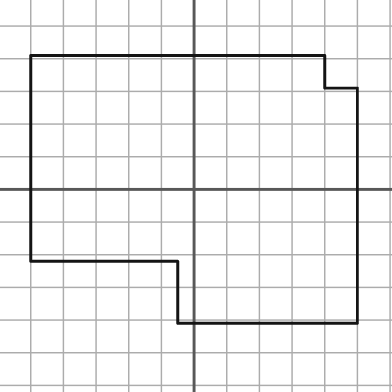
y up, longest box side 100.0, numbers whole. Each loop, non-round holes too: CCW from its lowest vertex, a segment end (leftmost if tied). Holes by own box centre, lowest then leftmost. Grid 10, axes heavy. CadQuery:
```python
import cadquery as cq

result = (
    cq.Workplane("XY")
    .moveTo(-5.0, -41.0)
    .lineTo(50.0, -41.0)
    .lineTo(50.0, 31.0)
    .lineTo(40.0, 31.0)
    .lineTo(40.0, 41.0)
    .lineTo(-50.0, 41.0)
    .lineTo(-50.0, -22.0)
    .lineTo(-5.0, -22.0)
    .close()
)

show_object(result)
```